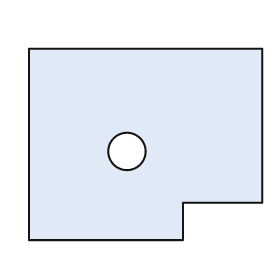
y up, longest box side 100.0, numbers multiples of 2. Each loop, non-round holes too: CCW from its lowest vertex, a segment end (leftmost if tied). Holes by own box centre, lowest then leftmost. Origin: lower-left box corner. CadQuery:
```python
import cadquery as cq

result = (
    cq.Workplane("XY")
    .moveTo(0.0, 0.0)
    .lineTo(66.0, 0.0)
    .lineTo(66.0, 16.0)
    .lineTo(100.0, 16.0)
    .lineTo(100.0, 82.0)
    .lineTo(0.0, 82.0)
    .close()
    .moveTo(42.0, 38.0)
    .circle(8.0)
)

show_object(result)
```